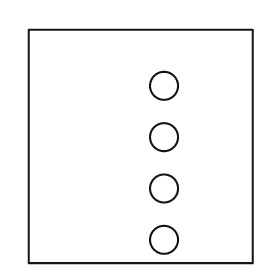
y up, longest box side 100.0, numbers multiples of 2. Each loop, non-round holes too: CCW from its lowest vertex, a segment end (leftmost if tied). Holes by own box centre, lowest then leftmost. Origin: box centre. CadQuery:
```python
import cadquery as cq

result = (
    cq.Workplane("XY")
    .moveTo(-48.0, -50.0)
    .lineTo(48.0, -50.0)
    .lineTo(48.0, 50.0)
    .lineTo(-48.0, 50.0)
    .close()
    .moveTo(10.0, -40.0)
    .circle(6.0)
    .moveTo(10.0, -18.0)
    .circle(6.0)
    .moveTo(10.0, 4.0)
    .circle(6.0)
    .moveTo(10.0, 26.0)
    .circle(6.0)
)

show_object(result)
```